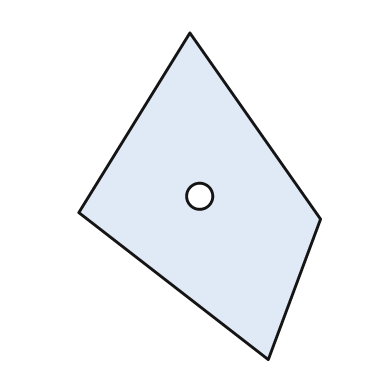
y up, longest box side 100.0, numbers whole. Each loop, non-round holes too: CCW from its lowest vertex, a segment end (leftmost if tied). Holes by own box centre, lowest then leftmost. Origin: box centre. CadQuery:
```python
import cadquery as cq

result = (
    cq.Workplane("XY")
    .moveTo(21.0, -50.0)
    .lineTo(37.0, -7.0)
    .lineTo(-3.0, 50.0)
    .lineTo(-37.0, -5.0)
    .close()
    .moveTo(0.0, 0.0)
    .circle(4.0)
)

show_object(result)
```